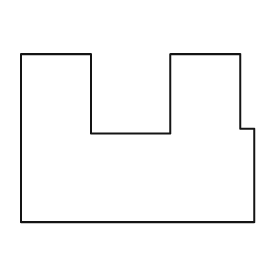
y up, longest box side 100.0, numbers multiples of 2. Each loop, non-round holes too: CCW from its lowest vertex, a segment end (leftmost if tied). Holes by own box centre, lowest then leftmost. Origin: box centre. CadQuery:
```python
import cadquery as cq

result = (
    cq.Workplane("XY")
    .moveTo(-50.0, -36.0)
    .lineTo(50.0, -36.0)
    .lineTo(50.0, 4.0)
    .lineTo(44.0, 4.0)
    .lineTo(44.0, 36.0)
    .lineTo(14.0, 36.0)
    .lineTo(14.0, 2.0)
    .lineTo(-20.0, 2.0)
    .lineTo(-20.0, 36.0)
    .lineTo(-50.0, 36.0)
    .close()
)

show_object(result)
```